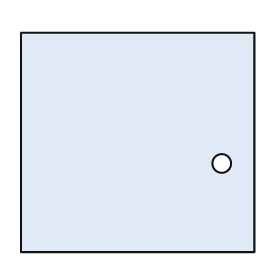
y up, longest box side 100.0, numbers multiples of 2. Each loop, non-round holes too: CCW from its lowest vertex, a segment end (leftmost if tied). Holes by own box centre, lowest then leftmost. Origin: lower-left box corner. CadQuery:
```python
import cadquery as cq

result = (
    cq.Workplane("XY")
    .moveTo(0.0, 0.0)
    .lineTo(100.0, 0.0)
    .lineTo(100.0, 94.0)
    .lineTo(0.0, 94.0)
    .close()
    .moveTo(86.0, 38.0)
    .circle(4.0)
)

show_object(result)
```